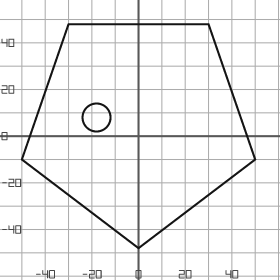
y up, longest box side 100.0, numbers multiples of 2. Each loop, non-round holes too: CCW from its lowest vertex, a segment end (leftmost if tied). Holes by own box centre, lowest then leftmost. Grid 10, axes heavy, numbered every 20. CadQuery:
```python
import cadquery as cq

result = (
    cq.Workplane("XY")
    .moveTo(0.0, -48.0)
    .lineTo(50.0, -10.0)
    .lineTo(30.0, 48.0)
    .lineTo(-30.0, 48.0)
    .lineTo(-50.0, -10.0)
    .close()
    .moveTo(-18.0, 8.0)
    .circle(6.0)
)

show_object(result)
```